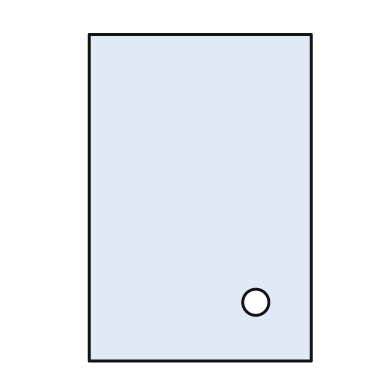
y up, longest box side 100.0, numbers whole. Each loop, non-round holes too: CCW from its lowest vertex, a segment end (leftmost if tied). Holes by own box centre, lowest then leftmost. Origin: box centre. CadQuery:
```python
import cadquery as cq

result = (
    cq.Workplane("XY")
    .moveTo(-34.0, -50.0)
    .lineTo(34.0, -50.0)
    .lineTo(34.0, 50.0)
    .lineTo(-34.0, 50.0)
    .close()
    .moveTo(17.0, -32.0)
    .circle(4.0)
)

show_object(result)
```